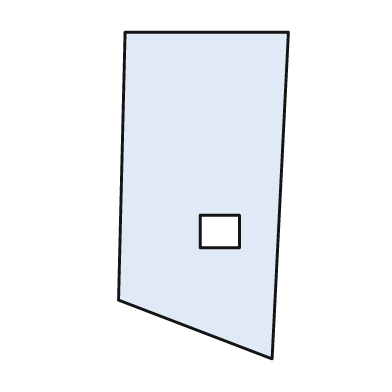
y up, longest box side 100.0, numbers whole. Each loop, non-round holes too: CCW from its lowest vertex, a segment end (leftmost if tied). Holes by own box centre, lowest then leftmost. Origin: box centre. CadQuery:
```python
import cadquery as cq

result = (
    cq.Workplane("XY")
    .moveTo(21.0, -50.0)
    .lineTo(26.0, 50.0)
    .lineTo(-24.0, 50.0)
    .lineTo(-26.0, -32.0)
    .close()
    .moveTo(-1.0, -16.0)
    .lineTo(11.0, -16.0)
    .lineTo(11.0, -6.0)
    .lineTo(-1.0, -6.0)
    .close()
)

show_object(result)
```